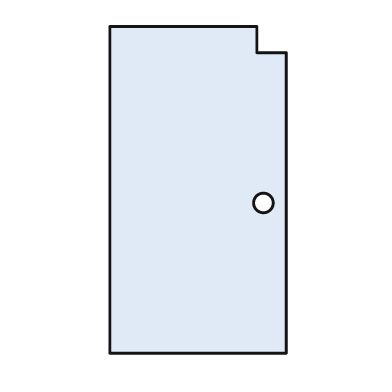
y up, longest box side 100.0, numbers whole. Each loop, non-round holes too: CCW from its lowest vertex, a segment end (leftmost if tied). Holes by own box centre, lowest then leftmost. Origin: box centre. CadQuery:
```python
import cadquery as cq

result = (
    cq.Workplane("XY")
    .moveTo(-27.0, -50.0)
    .lineTo(27.0, -50.0)
    .lineTo(27.0, 42.0)
    .lineTo(18.0, 42.0)
    .lineTo(18.0, 50.0)
    .lineTo(-27.0, 50.0)
    .close()
    .moveTo(20.0, -4.0)
    .circle(3.0)
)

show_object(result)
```